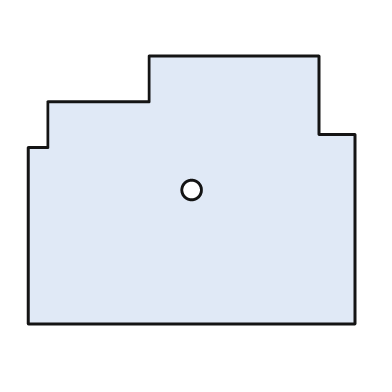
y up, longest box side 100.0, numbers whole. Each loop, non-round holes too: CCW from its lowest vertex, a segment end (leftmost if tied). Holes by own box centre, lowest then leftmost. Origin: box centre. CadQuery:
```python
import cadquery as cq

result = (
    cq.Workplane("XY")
    .moveTo(-50.0, -41.0)
    .lineTo(50.0, -41.0)
    .lineTo(50.0, 17.0)
    .lineTo(39.0, 17.0)
    .lineTo(39.0, 41.0)
    .lineTo(-13.0, 41.0)
    .lineTo(-13.0, 27.0)
    .lineTo(-44.0, 27.0)
    .lineTo(-44.0, 13.0)
    .lineTo(-50.0, 13.0)
    .close()
    .moveTo(0.0, 0.0)
    .circle(3.0)
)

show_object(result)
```